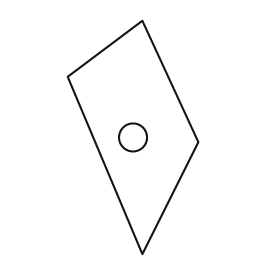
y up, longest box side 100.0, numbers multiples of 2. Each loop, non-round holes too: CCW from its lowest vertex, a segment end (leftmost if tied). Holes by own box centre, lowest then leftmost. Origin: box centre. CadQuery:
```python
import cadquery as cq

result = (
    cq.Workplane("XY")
    .moveTo(4.0, -50.0)
    .lineTo(28.0, -2.0)
    .lineTo(4.0, 50.0)
    .lineTo(-28.0, 26.0)
    .close()
    .moveTo(0.0, 0.0)
    .circle(6.0)
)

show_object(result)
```